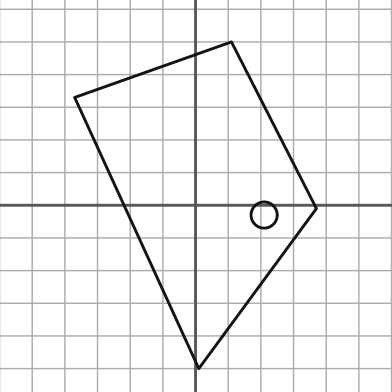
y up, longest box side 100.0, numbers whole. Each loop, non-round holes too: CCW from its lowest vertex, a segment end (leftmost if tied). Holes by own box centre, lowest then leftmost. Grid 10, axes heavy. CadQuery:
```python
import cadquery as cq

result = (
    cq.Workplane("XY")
    .moveTo(1.0, -50.0)
    .lineTo(37.0, -1.0)
    .lineTo(11.0, 50.0)
    .lineTo(-37.0, 33.0)
    .close()
    .moveTo(21.0, -3.0)
    .circle(4.0)
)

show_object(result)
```